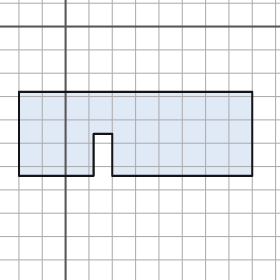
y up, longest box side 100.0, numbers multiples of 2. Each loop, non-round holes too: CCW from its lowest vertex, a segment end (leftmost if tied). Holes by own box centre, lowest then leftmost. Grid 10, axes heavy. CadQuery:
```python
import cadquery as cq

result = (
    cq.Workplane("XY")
    .moveTo(-20.0, -64.0)
    .lineTo(12.0, -64.0)
    .lineTo(12.0, -46.0)
    .lineTo(20.0, -46.0)
    .lineTo(20.0, -64.0)
    .lineTo(80.0, -64.0)
    .lineTo(80.0, -28.0)
    .lineTo(-20.0, -28.0)
    .close()
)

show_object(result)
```